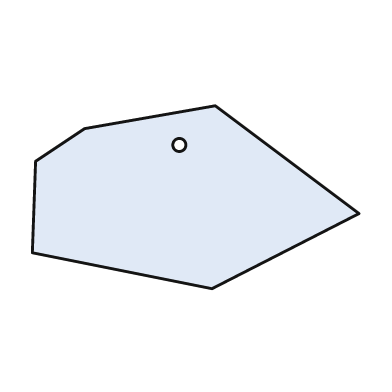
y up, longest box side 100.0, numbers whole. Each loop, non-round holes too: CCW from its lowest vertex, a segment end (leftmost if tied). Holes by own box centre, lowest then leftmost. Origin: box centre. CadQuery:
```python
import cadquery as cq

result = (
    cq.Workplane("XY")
    .moveTo(5.0, -28.0)
    .lineTo(50.0, -5.0)
    .lineTo(6.0, 28.0)
    .lineTo(-34.0, 21.0)
    .lineTo(-49.0, 11.0)
    .lineTo(-50.0, -17.0)
    .close()
    .moveTo(-5.0, 16.0)
    .circle(2.0)
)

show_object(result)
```